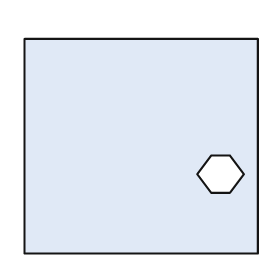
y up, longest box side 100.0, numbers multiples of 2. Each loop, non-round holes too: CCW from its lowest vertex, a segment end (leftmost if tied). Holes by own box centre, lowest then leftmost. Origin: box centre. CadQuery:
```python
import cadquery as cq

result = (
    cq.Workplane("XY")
    .moveTo(-50.0, -46.0)
    .lineTo(50.0, -46.0)
    .lineTo(50.0, 46.0)
    .lineTo(-50.0, 46.0)
    .close()
    .moveTo(30.0, -20.0)
    .lineTo(38.0, -20.0)
    .lineTo(44.0, -12.0)
    .lineTo(38.0, -4.0)
    .lineTo(30.0, -4.0)
    .lineTo(24.0, -12.0)
    .close()
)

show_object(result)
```